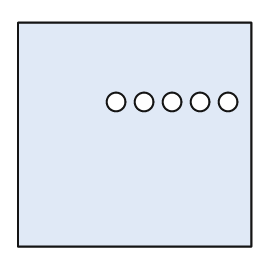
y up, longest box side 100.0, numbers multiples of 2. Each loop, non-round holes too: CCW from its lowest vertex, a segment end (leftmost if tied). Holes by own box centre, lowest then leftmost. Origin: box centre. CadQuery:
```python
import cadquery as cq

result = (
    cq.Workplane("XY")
    .moveTo(-50.0, -48.0)
    .lineTo(50.0, -48.0)
    .lineTo(50.0, 48.0)
    .lineTo(-50.0, 48.0)
    .close()
    .moveTo(-8.0, 14.0)
    .circle(4.0)
    .moveTo(4.0, 14.0)
    .circle(4.0)
    .moveTo(16.0, 14.0)
    .circle(4.0)
    .moveTo(28.0, 14.0)
    .circle(4.0)
    .moveTo(40.0, 14.0)
    .circle(4.0)
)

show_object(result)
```